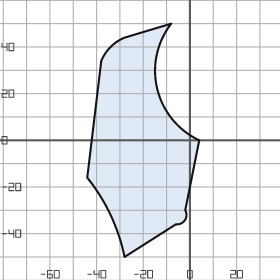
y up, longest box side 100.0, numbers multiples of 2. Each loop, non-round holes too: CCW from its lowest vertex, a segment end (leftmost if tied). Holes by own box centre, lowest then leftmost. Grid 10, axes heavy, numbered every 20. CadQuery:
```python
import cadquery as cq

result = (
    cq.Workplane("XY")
    .moveTo(-28.0, -50.0)
    .lineTo(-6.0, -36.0)
    .threePointArc((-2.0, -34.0), (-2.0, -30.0))
    .lineTo(4.0, 0.0)
    .threePointArc((-14.0, 22.0), (-8.0, 50.0))
    .lineTo(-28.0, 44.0)
    .threePointArc((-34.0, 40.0), (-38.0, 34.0))
    .lineTo(-44.0, -16.0)
    .threePointArc((-34.0, -32.0), (-28.0, -50.0))
    .close()
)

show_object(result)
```